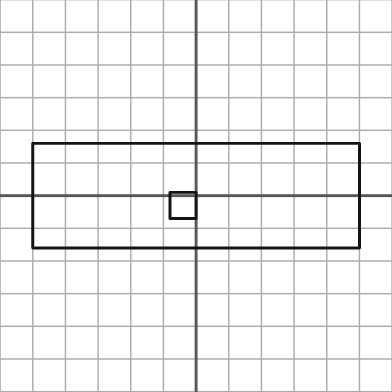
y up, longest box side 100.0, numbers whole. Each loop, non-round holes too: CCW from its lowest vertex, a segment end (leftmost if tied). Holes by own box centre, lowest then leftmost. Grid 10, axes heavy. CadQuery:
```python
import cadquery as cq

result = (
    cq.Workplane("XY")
    .moveTo(-50.0, -16.0)
    .lineTo(50.0, -16.0)
    .lineTo(50.0, 16.0)
    .lineTo(-50.0, 16.0)
    .close()
    .moveTo(-8.0, -7.0)
    .lineTo(0.0, -7.0)
    .lineTo(0.0, 1.0)
    .lineTo(-8.0, 1.0)
    .close()
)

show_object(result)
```